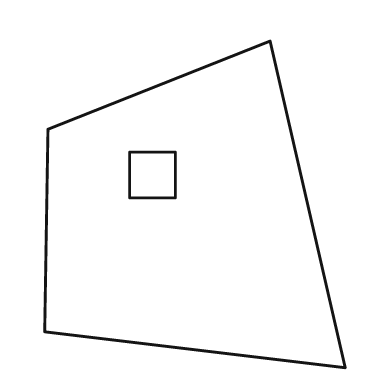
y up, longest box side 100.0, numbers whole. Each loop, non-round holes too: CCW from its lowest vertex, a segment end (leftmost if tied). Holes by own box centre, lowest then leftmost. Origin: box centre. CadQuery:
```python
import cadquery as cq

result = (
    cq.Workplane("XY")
    .moveTo(46.0, -50.0)
    .lineTo(23.0, 50.0)
    .lineTo(-45.0, 23.0)
    .lineTo(-46.0, -39.0)
    .close()
    .moveTo(-20.0, 2.0)
    .lineTo(-6.0, 2.0)
    .lineTo(-6.0, 16.0)
    .lineTo(-20.0, 16.0)
    .close()
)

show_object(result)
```